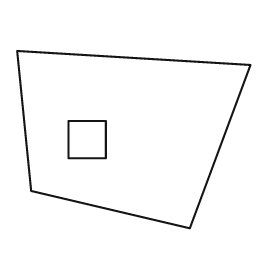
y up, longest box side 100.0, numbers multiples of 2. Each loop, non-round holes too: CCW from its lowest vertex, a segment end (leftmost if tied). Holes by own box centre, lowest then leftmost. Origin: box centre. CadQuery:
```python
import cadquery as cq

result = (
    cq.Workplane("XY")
    .moveTo(24.0, -38.0)
    .lineTo(50.0, 32.0)
    .lineTo(-50.0, 38.0)
    .lineTo(-44.0, -22.0)
    .close()
    .moveTo(-28.0, -8.0)
    .lineTo(-12.0, -8.0)
    .lineTo(-12.0, 8.0)
    .lineTo(-28.0, 8.0)
    .close()
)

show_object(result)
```